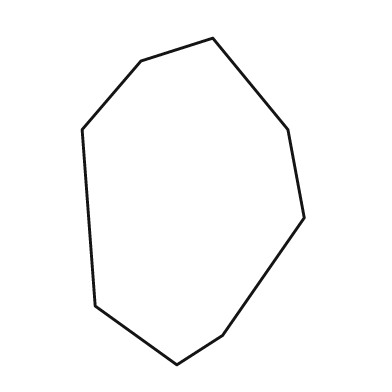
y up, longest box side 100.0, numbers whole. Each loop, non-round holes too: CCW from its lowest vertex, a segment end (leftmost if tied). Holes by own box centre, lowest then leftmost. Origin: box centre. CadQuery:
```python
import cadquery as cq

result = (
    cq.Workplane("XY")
    .moveTo(-5.0, -50.0)
    .lineTo(9.0, -41.0)
    .lineTo(34.0, -5.0)
    .lineTo(29.0, 22.0)
    .lineTo(6.0, 50.0)
    .lineTo(-16.0, 43.0)
    .lineTo(-34.0, 22.0)
    .lineTo(-30.0, -32.0)
    .close()
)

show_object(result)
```